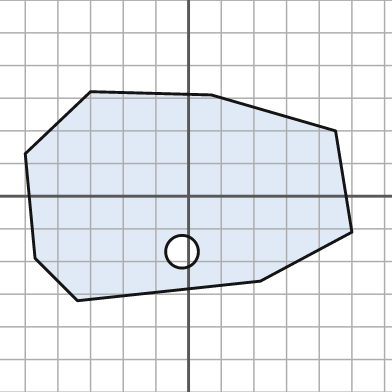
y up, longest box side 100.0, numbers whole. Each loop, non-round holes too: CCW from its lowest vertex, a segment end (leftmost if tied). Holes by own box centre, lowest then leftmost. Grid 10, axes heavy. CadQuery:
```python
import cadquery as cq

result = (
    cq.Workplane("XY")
    .moveTo(-34.0, -32.0)
    .lineTo(22.0, -26.0)
    .lineTo(50.0, -11.0)
    .lineTo(45.0, 20.0)
    .lineTo(7.0, 31.0)
    .lineTo(-30.0, 32.0)
    .lineTo(-50.0, 13.0)
    .lineTo(-47.0, -19.0)
    .close()
    .moveTo(-2.0, -17.0)
    .circle(5.0)
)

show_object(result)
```